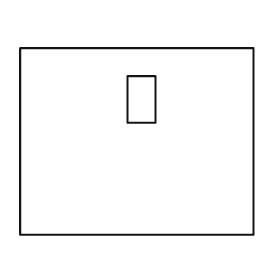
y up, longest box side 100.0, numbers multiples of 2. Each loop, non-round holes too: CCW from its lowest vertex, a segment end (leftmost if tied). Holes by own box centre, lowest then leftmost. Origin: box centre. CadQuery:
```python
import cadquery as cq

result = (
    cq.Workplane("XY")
    .moveTo(-50.0, -40.0)
    .lineTo(50.0, -40.0)
    .lineTo(50.0, 40.0)
    .lineTo(-50.0, 40.0)
    .close()
    .moveTo(-4.0, 8.0)
    .lineTo(8.0, 8.0)
    .lineTo(8.0, 28.0)
    .lineTo(-4.0, 28.0)
    .close()
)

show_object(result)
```